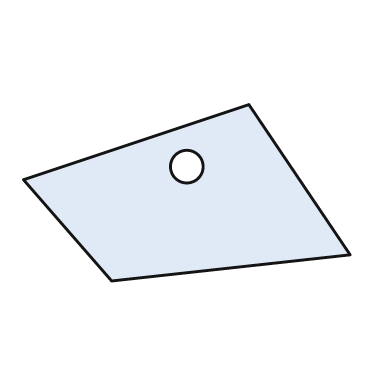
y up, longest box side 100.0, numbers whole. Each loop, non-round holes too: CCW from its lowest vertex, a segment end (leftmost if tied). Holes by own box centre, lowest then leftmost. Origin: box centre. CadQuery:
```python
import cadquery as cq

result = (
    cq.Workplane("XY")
    .moveTo(-23.0, -27.0)
    .lineTo(50.0, -19.0)
    .lineTo(19.0, 27.0)
    .lineTo(-50.0, 4.0)
    .close()
    .moveTo(0.0, 8.0)
    .circle(5.0)
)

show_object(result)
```